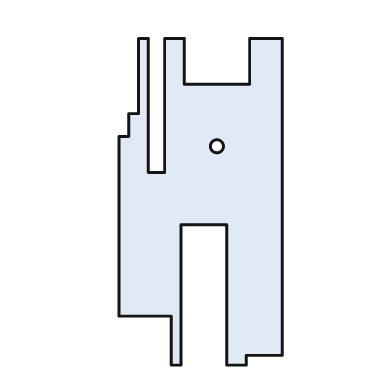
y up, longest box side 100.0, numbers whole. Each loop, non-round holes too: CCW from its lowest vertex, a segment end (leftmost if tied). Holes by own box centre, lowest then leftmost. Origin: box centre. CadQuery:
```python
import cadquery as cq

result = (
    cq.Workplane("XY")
    .moveTo(-9.0, -50.0)
    .lineTo(-6.0, -50.0)
    .lineTo(-6.0, -7.0)
    .lineTo(8.0, -7.0)
    .lineTo(8.0, -50.0)
    .lineTo(14.0, -50.0)
    .lineTo(14.0, -47.0)
    .lineTo(25.0, -47.0)
    .lineTo(25.0, 50.0)
    .lineTo(15.0, 50.0)
    .lineTo(15.0, 36.0)
    .lineTo(-5.0, 36.0)
    .lineTo(-5.0, 50.0)
    .lineTo(-11.0, 50.0)
    .lineTo(-11.0, 9.0)
    .lineTo(-16.0, 9.0)
    .lineTo(-16.0, 50.0)
    .lineTo(-19.0, 50.0)
    .lineTo(-19.0, 27.0)
    .lineTo(-22.0, 27.0)
    .lineTo(-22.0, 20.0)
    .lineTo(-25.0, 20.0)
    .lineTo(-25.0, -35.0)
    .lineTo(-9.0, -35.0)
    .close()
    .moveTo(5.0, 17.0)
    .circle(2.0)
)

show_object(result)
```